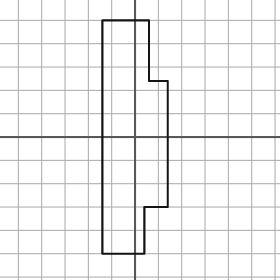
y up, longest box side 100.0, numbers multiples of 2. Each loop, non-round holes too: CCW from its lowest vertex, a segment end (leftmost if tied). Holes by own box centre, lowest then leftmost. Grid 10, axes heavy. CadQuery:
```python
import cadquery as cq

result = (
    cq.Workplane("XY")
    .moveTo(-14.0, -50.0)
    .lineTo(4.0, -50.0)
    .lineTo(4.0, -30.0)
    .lineTo(14.0, -30.0)
    .lineTo(14.0, 24.0)
    .lineTo(6.0, 24.0)
    .lineTo(6.0, 50.0)
    .lineTo(-14.0, 50.0)
    .close()
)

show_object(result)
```